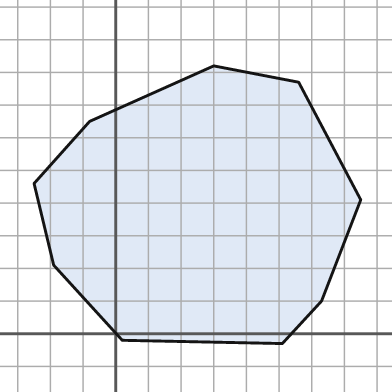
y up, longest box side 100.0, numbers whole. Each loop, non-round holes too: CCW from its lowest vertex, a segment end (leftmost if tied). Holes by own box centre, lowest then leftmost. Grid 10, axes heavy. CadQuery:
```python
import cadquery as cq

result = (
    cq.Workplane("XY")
    .moveTo(51.0, -3.0)
    .lineTo(63.0, 10.0)
    .lineTo(75.0, 41.0)
    .lineTo(56.0, 77.0)
    .lineTo(30.0, 82.0)
    .lineTo(-8.0, 65.0)
    .lineTo(-25.0, 46.0)
    .lineTo(-19.0, 21.0)
    .lineTo(2.0, -2.0)
    .close()
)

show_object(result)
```